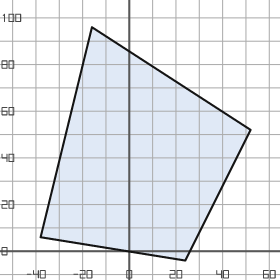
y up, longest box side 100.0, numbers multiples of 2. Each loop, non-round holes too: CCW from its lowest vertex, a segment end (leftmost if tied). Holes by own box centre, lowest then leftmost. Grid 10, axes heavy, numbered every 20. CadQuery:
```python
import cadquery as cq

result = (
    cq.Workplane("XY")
    .moveTo(24.0, -4.0)
    .lineTo(52.0, 52.0)
    .lineTo(-16.0, 96.0)
    .lineTo(-38.0, 6.0)
    .close()
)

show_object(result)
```